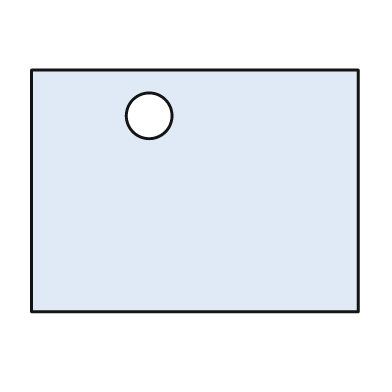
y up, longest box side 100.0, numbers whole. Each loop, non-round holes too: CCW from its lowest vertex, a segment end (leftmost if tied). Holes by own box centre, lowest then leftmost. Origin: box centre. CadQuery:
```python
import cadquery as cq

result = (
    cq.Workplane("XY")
    .moveTo(-50.0, -37.0)
    .lineTo(50.0, -37.0)
    .lineTo(50.0, 37.0)
    .lineTo(-50.0, 37.0)
    .close()
    .moveTo(-14.0, 23.0)
    .circle(7.0)
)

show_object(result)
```